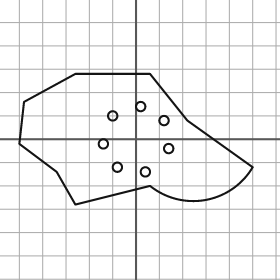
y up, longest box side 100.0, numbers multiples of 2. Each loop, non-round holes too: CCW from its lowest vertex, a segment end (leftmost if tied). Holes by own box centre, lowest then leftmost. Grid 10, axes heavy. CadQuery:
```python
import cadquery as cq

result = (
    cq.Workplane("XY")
    .moveTo(-26.0, -28.0)
    .lineTo(6.0, -20.0)
    .threePointArc((30.0, -26.0), (50.0, -12.0))
    .lineTo(22.0, 8.0)
    .lineTo(6.0, 28.0)
    .lineTo(-26.0, 28.0)
    .lineTo(-48.0, 16.0)
    .lineTo(-50.0, -2.0)
    .lineTo(-34.0, -14.0)
    .close()
    .moveTo(4.0, -14.0)
    .circle(2.0)
    .moveTo(-8.0, -12.0)
    .circle(2.0)
    .moveTo(14.0, -4.0)
    .circle(2.0)
    .moveTo(-14.0, -2.0)
    .circle(2.0)
    .moveTo(12.0, 8.0)
    .circle(2.0)
    .moveTo(-10.0, 10.0)
    .circle(2.0)
    .moveTo(2.0, 14.0)
    .circle(2.0)
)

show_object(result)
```